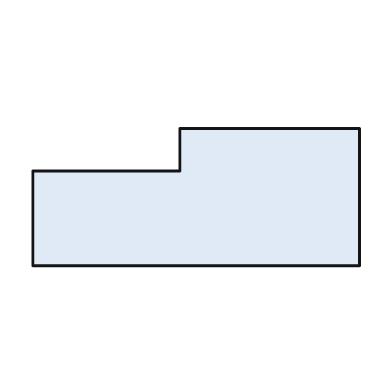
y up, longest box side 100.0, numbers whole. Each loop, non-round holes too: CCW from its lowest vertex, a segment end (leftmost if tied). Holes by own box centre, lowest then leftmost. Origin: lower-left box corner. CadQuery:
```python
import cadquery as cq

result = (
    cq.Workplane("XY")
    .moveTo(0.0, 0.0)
    .lineTo(100.0, 0.0)
    .lineTo(100.0, 42.0)
    .lineTo(45.0, 42.0)
    .lineTo(45.0, 29.0)
    .lineTo(0.0, 29.0)
    .close()
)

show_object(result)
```